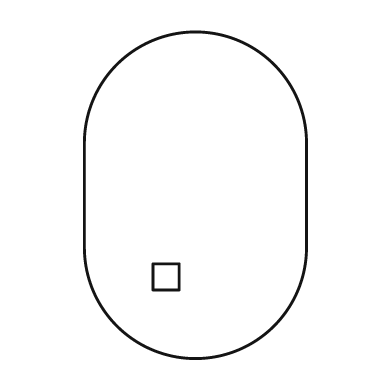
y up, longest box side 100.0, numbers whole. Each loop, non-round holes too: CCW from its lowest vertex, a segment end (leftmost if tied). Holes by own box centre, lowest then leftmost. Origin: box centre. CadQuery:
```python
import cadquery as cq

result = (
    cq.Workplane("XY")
    .moveTo(-34.0, -16.0)
    .threePointArc((0.0, -50.0), (34.0, -16.0))
    .lineTo(34.0, 16.0)
    .threePointArc((0.0, 50.0), (-34.0, 16.0))
    .close()
    .moveTo(-13.0, -29.0)
    .lineTo(-5.0, -29.0)
    .lineTo(-5.0, -21.0)
    .lineTo(-13.0, -21.0)
    .close()
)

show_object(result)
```